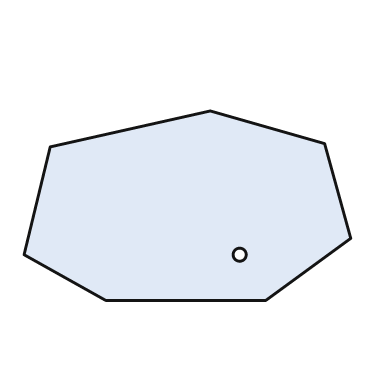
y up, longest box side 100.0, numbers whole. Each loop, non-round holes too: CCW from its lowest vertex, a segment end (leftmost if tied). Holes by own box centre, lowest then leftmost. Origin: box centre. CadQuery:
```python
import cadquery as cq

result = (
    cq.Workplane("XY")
    .moveTo(-25.0, -29.0)
    .lineTo(24.0, -29.0)
    .lineTo(50.0, -10.0)
    .lineTo(42.0, 19.0)
    .lineTo(7.0, 29.0)
    .lineTo(-42.0, 18.0)
    .lineTo(-50.0, -15.0)
    .close()
    .moveTo(16.0, -15.0)
    .circle(2.0)
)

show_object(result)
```